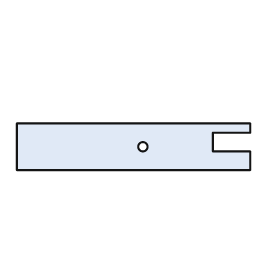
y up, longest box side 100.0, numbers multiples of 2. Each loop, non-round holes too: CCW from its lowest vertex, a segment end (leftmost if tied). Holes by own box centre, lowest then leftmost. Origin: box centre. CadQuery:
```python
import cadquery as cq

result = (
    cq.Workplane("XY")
    .moveTo(-50.0, -10.0)
    .lineTo(50.0, -10.0)
    .lineTo(50.0, -2.0)
    .lineTo(34.0, -2.0)
    .lineTo(34.0, 6.0)
    .lineTo(50.0, 6.0)
    .lineTo(50.0, 10.0)
    .lineTo(-50.0, 10.0)
    .close()
    .moveTo(4.0, 0.0)
    .circle(2.0)
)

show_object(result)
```